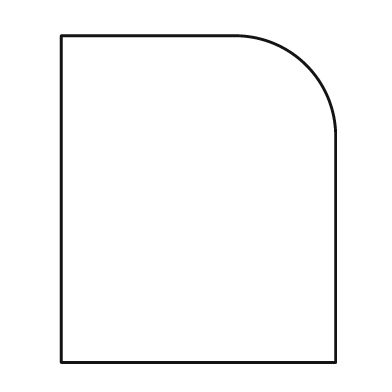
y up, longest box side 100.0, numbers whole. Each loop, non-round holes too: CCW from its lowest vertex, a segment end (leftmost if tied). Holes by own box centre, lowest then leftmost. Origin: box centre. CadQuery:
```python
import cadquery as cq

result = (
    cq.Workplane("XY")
    .moveTo(-42.0, -50.0)
    .lineTo(42.0, -50.0)
    .lineTo(42.0, 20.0)
    .threePointArc((33.0, 41.0), (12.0, 50.0))
    .lineTo(-42.0, 50.0)
    .close()
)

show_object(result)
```